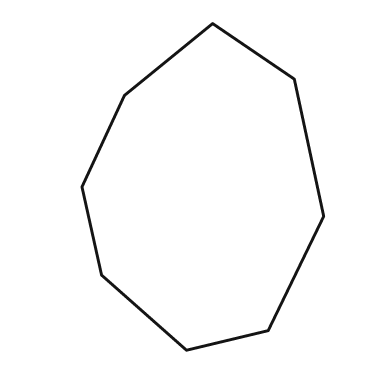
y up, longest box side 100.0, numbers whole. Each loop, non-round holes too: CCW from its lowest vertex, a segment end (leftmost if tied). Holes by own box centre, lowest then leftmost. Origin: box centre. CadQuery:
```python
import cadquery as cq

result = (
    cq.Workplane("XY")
    .moveTo(-5.0, -50.0)
    .lineTo(20.0, -44.0)
    .lineTo(37.0, -9.0)
    .lineTo(28.0, 33.0)
    .lineTo(3.0, 50.0)
    .lineTo(-24.0, 28.0)
    .lineTo(-37.0, 0.0)
    .lineTo(-31.0, -27.0)
    .close()
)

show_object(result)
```